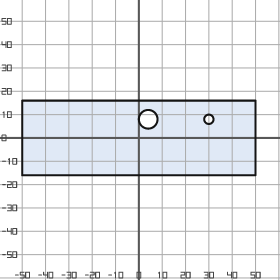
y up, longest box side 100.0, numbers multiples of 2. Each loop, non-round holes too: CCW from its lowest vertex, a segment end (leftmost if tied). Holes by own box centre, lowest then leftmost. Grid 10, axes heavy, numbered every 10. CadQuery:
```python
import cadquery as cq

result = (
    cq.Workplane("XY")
    .moveTo(-50.0, -16.0)
    .lineTo(50.0, -16.0)
    .lineTo(50.0, 16.0)
    .lineTo(-50.0, 16.0)
    .close()
    .moveTo(4.0, 8.0)
    .circle(4.0)
    .moveTo(30.0, 8.0)
    .circle(2.0)
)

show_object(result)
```